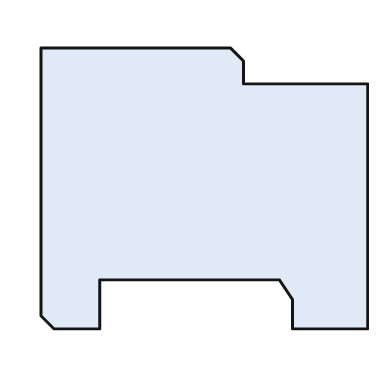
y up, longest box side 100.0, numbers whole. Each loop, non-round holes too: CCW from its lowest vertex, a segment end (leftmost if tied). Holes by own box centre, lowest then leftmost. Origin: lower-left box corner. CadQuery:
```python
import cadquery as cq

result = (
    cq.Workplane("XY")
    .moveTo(4.0, 0.0)
    .lineTo(18.0, 0.0)
    .lineTo(18.0, 15.0)
    .lineTo(73.0, 15.0)
    .lineTo(77.0, 9.0)
    .lineTo(77.0, 0.0)
    .lineTo(100.0, 0.0)
    .lineTo(100.0, 75.0)
    .lineTo(62.0, 75.0)
    .lineTo(62.0, 82.0)
    .lineTo(58.0, 86.0)
    .lineTo(0.0, 86.0)
    .lineTo(0.0, 4.0)
    .close()
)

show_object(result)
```